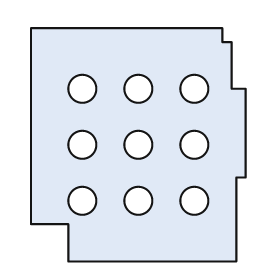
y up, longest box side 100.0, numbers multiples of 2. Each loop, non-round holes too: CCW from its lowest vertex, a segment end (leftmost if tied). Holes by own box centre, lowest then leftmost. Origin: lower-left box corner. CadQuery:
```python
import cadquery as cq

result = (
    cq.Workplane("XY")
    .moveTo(16.0, 0.0)
    .lineTo(88.0, 0.0)
    .lineTo(88.0, 36.0)
    .lineTo(92.0, 36.0)
    .lineTo(92.0, 74.0)
    .lineTo(86.0, 74.0)
    .lineTo(86.0, 94.0)
    .lineTo(82.0, 94.0)
    .lineTo(82.0, 100.0)
    .lineTo(0.0, 100.0)
    .lineTo(0.0, 16.0)
    .lineTo(16.0, 16.0)
    .close()
    .moveTo(22.0, 26.0)
    .circle(6.0)
    .moveTo(46.0, 26.0)
    .circle(6.0)
    .moveTo(70.0, 26.0)
    .circle(6.0)
    .moveTo(22.0, 50.0)
    .circle(6.0)
    .moveTo(46.0, 50.0)
    .circle(6.0)
    .moveTo(70.0, 50.0)
    .circle(6.0)
    .moveTo(22.0, 74.0)
    .circle(6.0)
    .moveTo(46.0, 74.0)
    .circle(6.0)
    .moveTo(70.0, 74.0)
    .circle(6.0)
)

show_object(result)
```